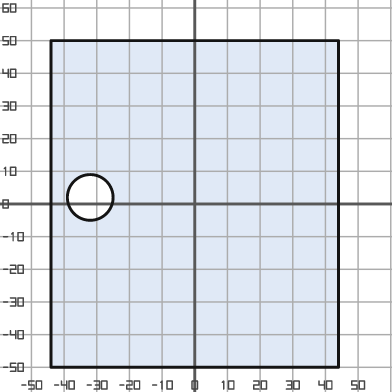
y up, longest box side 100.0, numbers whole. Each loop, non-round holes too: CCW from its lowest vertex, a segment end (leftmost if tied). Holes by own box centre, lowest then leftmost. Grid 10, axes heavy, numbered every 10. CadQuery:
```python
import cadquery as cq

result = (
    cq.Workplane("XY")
    .moveTo(-44.0, -50.0)
    .lineTo(44.0, -50.0)
    .lineTo(44.0, 50.0)
    .lineTo(-44.0, 50.0)
    .close()
    .moveTo(-32.0, 2.0)
    .circle(7.0)
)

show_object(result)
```